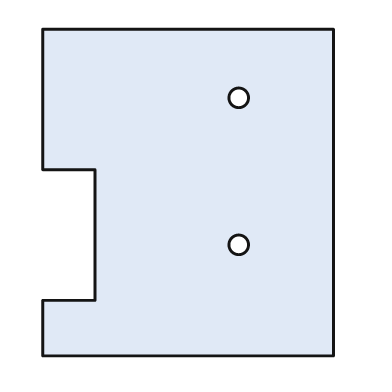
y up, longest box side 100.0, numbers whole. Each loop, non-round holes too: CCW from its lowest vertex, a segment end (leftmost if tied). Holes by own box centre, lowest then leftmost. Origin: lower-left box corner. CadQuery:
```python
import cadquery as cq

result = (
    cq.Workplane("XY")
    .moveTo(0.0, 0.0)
    .lineTo(89.0, 0.0)
    .lineTo(89.0, 100.0)
    .lineTo(0.0, 100.0)
    .lineTo(0.0, 57.0)
    .lineTo(16.0, 57.0)
    .lineTo(16.0, 17.0)
    .lineTo(0.0, 17.0)
    .close()
    .moveTo(60.0, 34.0)
    .circle(3.0)
    .moveTo(60.0, 79.0)
    .circle(3.0)
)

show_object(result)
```